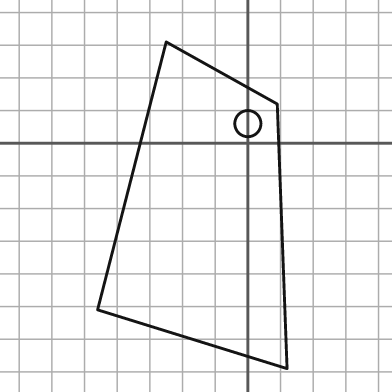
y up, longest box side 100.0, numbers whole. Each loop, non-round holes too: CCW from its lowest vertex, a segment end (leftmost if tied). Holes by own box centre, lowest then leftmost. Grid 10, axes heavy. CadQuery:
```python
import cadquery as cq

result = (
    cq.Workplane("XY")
    .moveTo(12.0, -69.0)
    .lineTo(9.0, 12.0)
    .lineTo(-25.0, 31.0)
    .lineTo(-46.0, -51.0)
    .close()
    .moveTo(0.0, 6.0)
    .circle(4.0)
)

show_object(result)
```